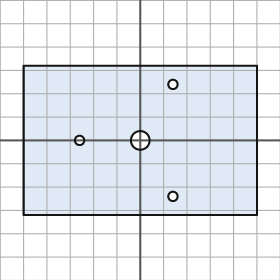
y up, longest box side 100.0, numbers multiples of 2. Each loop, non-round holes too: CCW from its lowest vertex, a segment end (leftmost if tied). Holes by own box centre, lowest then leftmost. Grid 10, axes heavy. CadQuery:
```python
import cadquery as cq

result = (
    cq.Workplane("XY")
    .moveTo(-50.0, -32.0)
    .lineTo(50.0, -32.0)
    .lineTo(50.0, 32.0)
    .lineTo(-50.0, 32.0)
    .close()
    .moveTo(14.0, -24.0)
    .circle(2.0)
    .moveTo(-26.0, 0.0)
    .circle(2.0)
    .moveTo(0.0, 0.0)
    .circle(4.0)
    .moveTo(14.0, 24.0)
    .circle(2.0)
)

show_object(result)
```